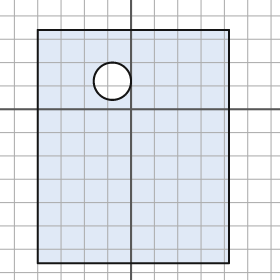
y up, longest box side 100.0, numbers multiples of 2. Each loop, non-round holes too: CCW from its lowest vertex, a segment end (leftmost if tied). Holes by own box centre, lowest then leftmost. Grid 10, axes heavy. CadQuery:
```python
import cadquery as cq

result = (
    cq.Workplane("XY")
    .moveTo(-40.0, -66.0)
    .lineTo(42.0, -66.0)
    .lineTo(42.0, 34.0)
    .lineTo(-40.0, 34.0)
    .close()
    .moveTo(-8.0, 12.0)
    .circle(8.0)
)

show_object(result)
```